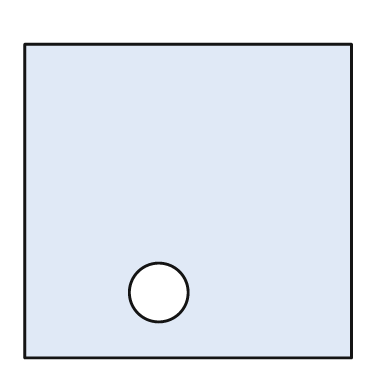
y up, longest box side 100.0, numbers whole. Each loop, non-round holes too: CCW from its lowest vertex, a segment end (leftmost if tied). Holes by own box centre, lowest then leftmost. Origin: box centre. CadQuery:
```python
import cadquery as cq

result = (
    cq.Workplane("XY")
    .moveTo(-50.0, -48.0)
    .lineTo(50.0, -48.0)
    .lineTo(50.0, 48.0)
    .lineTo(-50.0, 48.0)
    .close()
    .moveTo(-9.0, -28.0)
    .circle(9.0)
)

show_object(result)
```